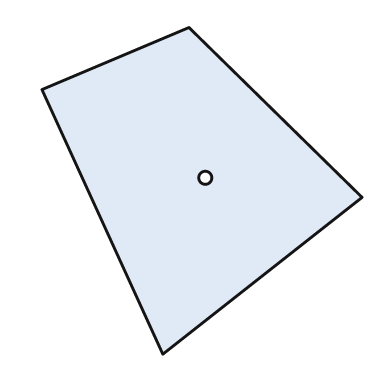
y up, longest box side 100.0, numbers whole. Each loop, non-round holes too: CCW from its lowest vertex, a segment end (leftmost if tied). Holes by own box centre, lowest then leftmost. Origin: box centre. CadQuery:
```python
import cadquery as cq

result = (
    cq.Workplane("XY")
    .moveTo(-12.0, -50.0)
    .lineTo(49.0, -2.0)
    .lineTo(-4.0, 50.0)
    .lineTo(-49.0, 31.0)
    .close()
    .moveTo(1.0, 4.0)
    .circle(2.0)
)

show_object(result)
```